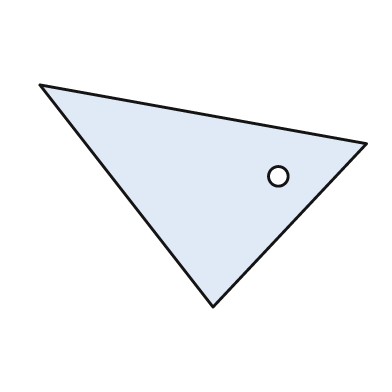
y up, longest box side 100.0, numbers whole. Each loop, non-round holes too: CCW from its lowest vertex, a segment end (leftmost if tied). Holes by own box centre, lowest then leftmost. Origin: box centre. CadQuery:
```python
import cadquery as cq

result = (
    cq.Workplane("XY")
    .moveTo(3.0, -34.0)
    .lineTo(50.0, 16.0)
    .lineTo(-50.0, 34.0)
    .close()
    .moveTo(23.0, 6.0)
    .circle(3.0)
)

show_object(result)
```